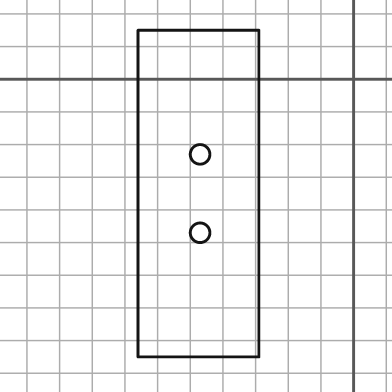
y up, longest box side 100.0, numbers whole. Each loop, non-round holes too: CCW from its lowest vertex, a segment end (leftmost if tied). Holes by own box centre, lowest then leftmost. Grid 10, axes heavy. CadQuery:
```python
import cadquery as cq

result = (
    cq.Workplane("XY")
    .moveTo(-66.0, -85.0)
    .lineTo(-29.0, -85.0)
    .lineTo(-29.0, 15.0)
    .lineTo(-66.0, 15.0)
    .close()
    .moveTo(-47.0, -47.0)
    .circle(3.0)
    .moveTo(-47.0, -23.0)
    .circle(3.0)
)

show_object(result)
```